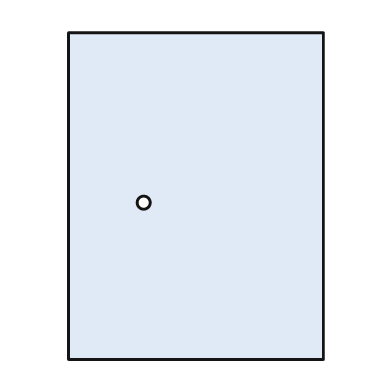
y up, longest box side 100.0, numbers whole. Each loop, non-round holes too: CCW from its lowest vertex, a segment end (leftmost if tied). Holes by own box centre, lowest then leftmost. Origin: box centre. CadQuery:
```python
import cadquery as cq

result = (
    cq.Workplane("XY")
    .moveTo(-39.0, -50.0)
    .lineTo(39.0, -50.0)
    .lineTo(39.0, 50.0)
    .lineTo(-39.0, 50.0)
    .close()
    .moveTo(-16.0, -2.0)
    .circle(2.0)
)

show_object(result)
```